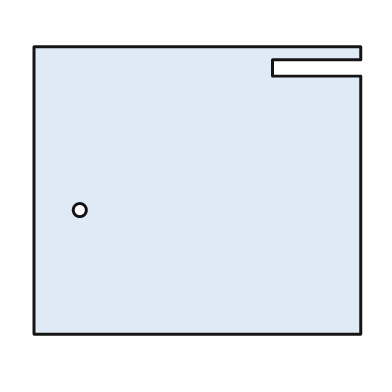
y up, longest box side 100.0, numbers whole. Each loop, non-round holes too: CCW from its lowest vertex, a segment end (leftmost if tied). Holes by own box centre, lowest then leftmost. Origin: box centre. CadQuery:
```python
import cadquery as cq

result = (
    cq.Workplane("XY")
    .moveTo(-50.0, -44.0)
    .lineTo(50.0, -44.0)
    .lineTo(50.0, 35.0)
    .lineTo(23.0, 35.0)
    .lineTo(23.0, 40.0)
    .lineTo(50.0, 40.0)
    .lineTo(50.0, 44.0)
    .lineTo(-50.0, 44.0)
    .close()
    .moveTo(-36.0, -6.0)
    .circle(2.0)
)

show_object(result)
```